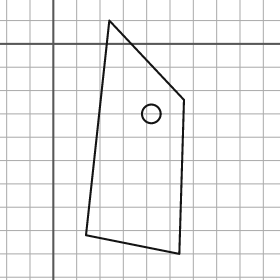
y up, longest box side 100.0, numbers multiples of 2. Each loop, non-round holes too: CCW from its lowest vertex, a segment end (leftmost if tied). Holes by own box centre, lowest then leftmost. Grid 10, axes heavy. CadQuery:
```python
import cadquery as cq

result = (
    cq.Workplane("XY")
    .moveTo(54.0, -90.0)
    .lineTo(56.0, -24.0)
    .lineTo(24.0, 10.0)
    .lineTo(14.0, -82.0)
    .close()
    .moveTo(42.0, -30.0)
    .circle(4.0)
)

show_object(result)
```